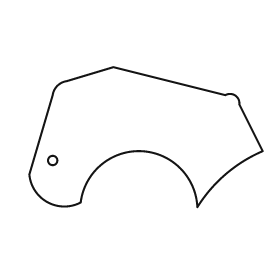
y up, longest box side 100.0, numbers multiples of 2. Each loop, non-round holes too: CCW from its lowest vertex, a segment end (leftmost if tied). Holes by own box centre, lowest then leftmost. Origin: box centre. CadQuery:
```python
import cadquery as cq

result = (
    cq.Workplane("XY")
    .moveTo(22.0, -30.0)
    .threePointArc((34.0, -16.0), (50.0, -6.0))
    .lineTo(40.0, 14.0)
    .threePointArc((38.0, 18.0), (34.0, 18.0))
    .lineTo(-14.0, 30.0)
    .lineTo(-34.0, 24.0)
    .threePointArc((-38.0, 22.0), (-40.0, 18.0))
    .lineTo(-50.0, -16.0)
    .threePointArc((-42.0, -28.0), (-28.0, -28.0))
    .threePointArc((-2.0, -6.0), (22.0, -30.0))
    .close()
    .moveTo(-40.0, -10.0)
    .circle(2.0)
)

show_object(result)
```